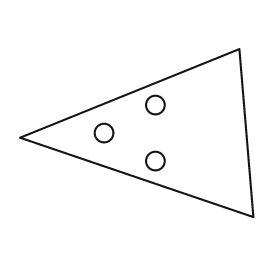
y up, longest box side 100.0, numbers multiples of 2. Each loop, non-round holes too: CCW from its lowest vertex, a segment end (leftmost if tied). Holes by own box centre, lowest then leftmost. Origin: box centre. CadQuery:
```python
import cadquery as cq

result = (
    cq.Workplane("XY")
    .moveTo(50.0, -36.0)
    .lineTo(44.0, 36.0)
    .lineTo(-50.0, -2.0)
    .close()
    .moveTo(8.0, -12.0)
    .circle(4.0)
    .moveTo(-14.0, 0.0)
    .circle(4.0)
    .moveTo(8.0, 12.0)
    .circle(4.0)
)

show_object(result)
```